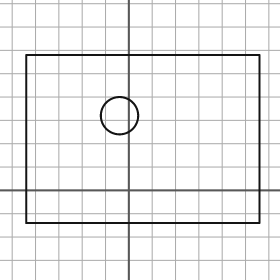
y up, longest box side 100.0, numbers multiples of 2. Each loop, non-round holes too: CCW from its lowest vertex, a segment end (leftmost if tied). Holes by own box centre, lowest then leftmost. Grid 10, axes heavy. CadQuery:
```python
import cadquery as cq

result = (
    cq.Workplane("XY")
    .moveTo(-44.0, -14.0)
    .lineTo(56.0, -14.0)
    .lineTo(56.0, 58.0)
    .lineTo(-44.0, 58.0)
    .close()
    .moveTo(-4.0, 32.0)
    .circle(8.0)
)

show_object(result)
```